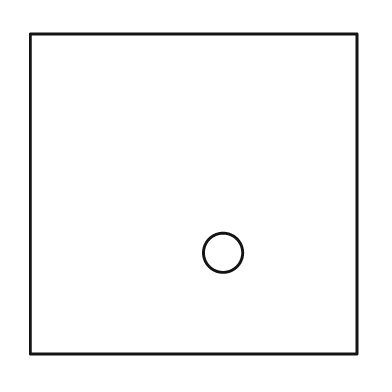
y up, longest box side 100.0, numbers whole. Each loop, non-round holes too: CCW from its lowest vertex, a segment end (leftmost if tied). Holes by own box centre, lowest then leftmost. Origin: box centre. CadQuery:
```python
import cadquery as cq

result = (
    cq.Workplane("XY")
    .moveTo(-50.0, -49.0)
    .lineTo(50.0, -49.0)
    .lineTo(50.0, 49.0)
    .lineTo(-50.0, 49.0)
    .close()
    .moveTo(9.0, -18.0)
    .circle(6.0)
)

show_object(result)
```